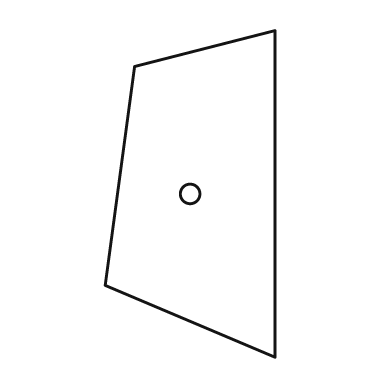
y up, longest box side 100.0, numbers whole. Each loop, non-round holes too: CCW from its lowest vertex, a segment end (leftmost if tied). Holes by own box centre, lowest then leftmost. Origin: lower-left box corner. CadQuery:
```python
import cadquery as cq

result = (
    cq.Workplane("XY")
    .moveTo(52.0, 0.0)
    .lineTo(52.0, 100.0)
    .lineTo(9.0, 89.0)
    .lineTo(0.0, 22.0)
    .close()
    .moveTo(26.0, 50.0)
    .circle(3.0)
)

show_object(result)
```